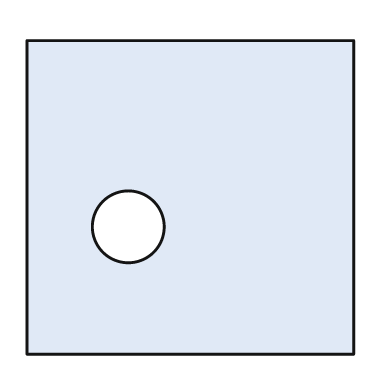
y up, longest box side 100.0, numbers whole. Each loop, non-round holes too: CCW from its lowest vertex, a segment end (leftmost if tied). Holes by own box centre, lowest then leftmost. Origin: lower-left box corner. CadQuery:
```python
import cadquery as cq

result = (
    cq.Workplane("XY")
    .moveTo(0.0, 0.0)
    .lineTo(100.0, 0.0)
    .lineTo(100.0, 96.0)
    .lineTo(0.0, 96.0)
    .close()
    .moveTo(31.0, 39.0)
    .circle(11.0)
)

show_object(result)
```